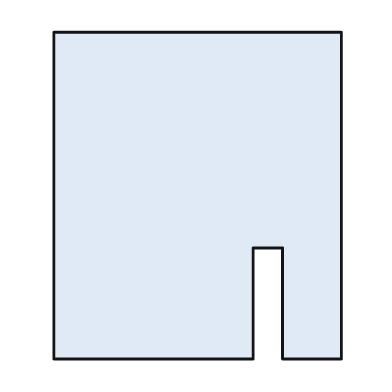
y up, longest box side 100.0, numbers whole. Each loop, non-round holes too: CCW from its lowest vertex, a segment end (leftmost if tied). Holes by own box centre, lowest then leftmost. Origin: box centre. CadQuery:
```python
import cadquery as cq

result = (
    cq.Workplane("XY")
    .moveTo(-44.0, -50.0)
    .lineTo(17.0, -50.0)
    .lineTo(17.0, -16.0)
    .lineTo(26.0, -16.0)
    .lineTo(26.0, -50.0)
    .lineTo(44.0, -50.0)
    .lineTo(44.0, 50.0)
    .lineTo(-44.0, 50.0)
    .close()
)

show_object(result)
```